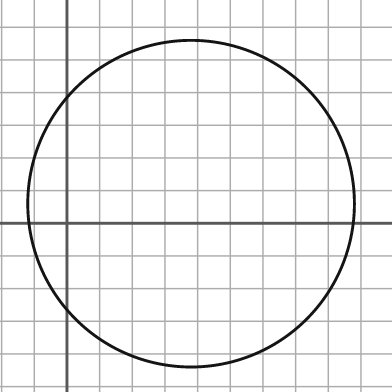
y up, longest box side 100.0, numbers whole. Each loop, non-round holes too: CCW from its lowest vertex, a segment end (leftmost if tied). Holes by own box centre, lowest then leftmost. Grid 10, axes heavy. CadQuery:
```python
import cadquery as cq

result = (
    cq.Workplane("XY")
    .moveTo(38.0, 6.0)
    .circle(50.0)
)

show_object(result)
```